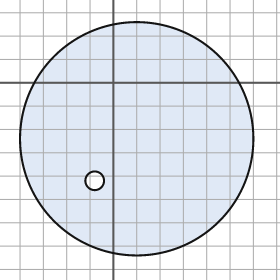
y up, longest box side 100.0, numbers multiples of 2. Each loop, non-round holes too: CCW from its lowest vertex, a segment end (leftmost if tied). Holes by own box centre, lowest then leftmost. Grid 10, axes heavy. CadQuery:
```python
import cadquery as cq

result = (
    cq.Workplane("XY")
    .moveTo(10.0, -24.0)
    .circle(50.0)
    .moveTo(-8.0, -42.0)
    .circle(4.0)
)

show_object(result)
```